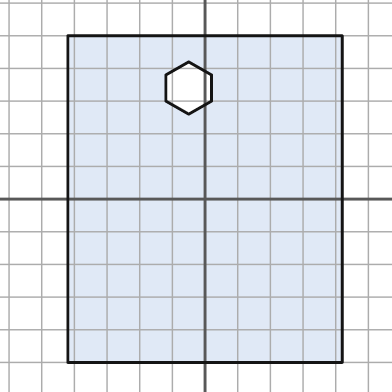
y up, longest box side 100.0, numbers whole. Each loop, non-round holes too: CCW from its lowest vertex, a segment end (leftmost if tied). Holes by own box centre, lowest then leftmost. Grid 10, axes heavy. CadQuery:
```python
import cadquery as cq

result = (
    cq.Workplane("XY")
    .moveTo(-42.0, -50.0)
    .lineTo(42.0, -50.0)
    .lineTo(42.0, 50.0)
    .lineTo(-42.0, 50.0)
    .close()
    .moveTo(-5.0, 26.0)
    .lineTo(2.0, 30.0)
    .lineTo(2.0, 38.0)
    .lineTo(-5.0, 42.0)
    .lineTo(-12.0, 38.0)
    .lineTo(-12.0, 30.0)
    .close()
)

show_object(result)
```